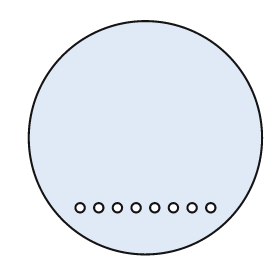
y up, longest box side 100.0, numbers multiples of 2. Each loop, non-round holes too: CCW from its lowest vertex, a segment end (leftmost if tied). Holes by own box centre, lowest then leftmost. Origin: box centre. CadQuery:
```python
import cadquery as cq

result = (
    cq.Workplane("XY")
    .moveTo(0.0, 0.0)
    .circle(50.0)
    .moveTo(-28.0, -30.0)
    .circle(2.0)
    .moveTo(-20.0, -30.0)
    .circle(2.0)
    .moveTo(-12.0, -30.0)
    .circle(2.0)
    .moveTo(-4.0, -30.0)
    .circle(2.0)
    .moveTo(4.0, -30.0)
    .circle(2.0)
    .moveTo(12.0, -30.0)
    .circle(2.0)
    .moveTo(20.0, -30.0)
    .circle(2.0)
    .moveTo(28.0, -30.0)
    .circle(2.0)
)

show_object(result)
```